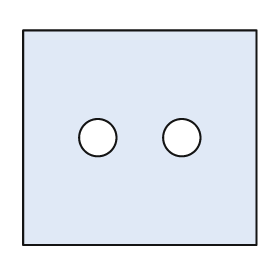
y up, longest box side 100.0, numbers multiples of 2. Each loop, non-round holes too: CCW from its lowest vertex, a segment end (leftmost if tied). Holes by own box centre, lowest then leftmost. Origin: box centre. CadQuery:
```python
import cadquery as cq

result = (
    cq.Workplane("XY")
    .moveTo(-50.0, -46.0)
    .lineTo(50.0, -46.0)
    .lineTo(50.0, 46.0)
    .lineTo(-50.0, 46.0)
    .close()
    .moveTo(-18.0, 0.0)
    .circle(8.0)
    .moveTo(18.0, 0.0)
    .circle(8.0)
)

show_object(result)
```